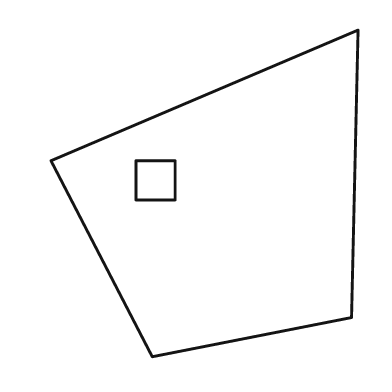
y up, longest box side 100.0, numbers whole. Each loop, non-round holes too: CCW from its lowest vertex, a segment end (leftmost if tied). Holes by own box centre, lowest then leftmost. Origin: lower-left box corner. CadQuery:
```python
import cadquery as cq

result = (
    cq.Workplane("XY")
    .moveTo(31.0, 0.0)
    .lineTo(92.0, 12.0)
    .lineTo(94.0, 100.0)
    .lineTo(0.0, 60.0)
    .close()
    .moveTo(26.0, 48.0)
    .lineTo(38.0, 48.0)
    .lineTo(38.0, 60.0)
    .lineTo(26.0, 60.0)
    .close()
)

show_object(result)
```